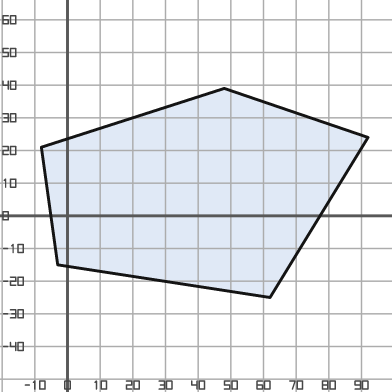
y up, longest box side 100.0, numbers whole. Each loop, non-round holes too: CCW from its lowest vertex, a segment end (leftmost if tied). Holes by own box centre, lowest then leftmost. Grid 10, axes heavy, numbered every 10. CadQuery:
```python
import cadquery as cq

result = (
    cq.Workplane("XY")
    .moveTo(62.0, -25.0)
    .lineTo(92.0, 24.0)
    .lineTo(48.0, 39.0)
    .lineTo(-8.0, 21.0)
    .lineTo(-3.0, -15.0)
    .close()
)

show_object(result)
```